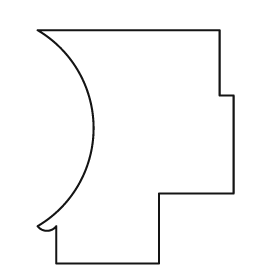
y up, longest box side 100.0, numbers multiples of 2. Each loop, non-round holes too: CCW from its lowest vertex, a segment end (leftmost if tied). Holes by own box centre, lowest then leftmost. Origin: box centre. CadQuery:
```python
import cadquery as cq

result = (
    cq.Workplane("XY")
    .moveTo(-34.0, -50.0)
    .lineTo(10.0, -50.0)
    .lineTo(10.0, -20.0)
    .lineTo(42.0, -20.0)
    .lineTo(42.0, 22.0)
    .lineTo(36.0, 22.0)
    .lineTo(36.0, 50.0)
    .lineTo(-42.0, 50.0)
    .threePointArc((-18.0, 8.0), (-42.0, -34.0))
    .threePointArc((-38.0, -36.0), (-34.0, -34.0))
    .close()
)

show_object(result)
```